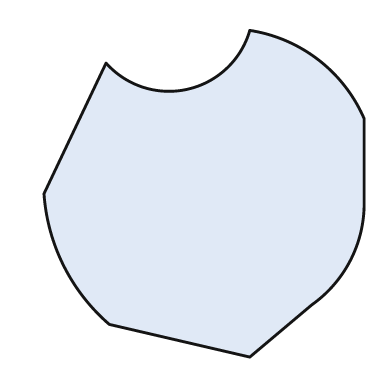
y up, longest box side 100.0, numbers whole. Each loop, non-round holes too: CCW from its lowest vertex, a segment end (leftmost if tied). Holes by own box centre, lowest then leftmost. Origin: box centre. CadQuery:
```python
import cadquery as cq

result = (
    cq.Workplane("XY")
    .moveTo(14.0, -50.0)
    .lineTo(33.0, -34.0)
    .threePointArc((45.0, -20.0), (49.0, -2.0))
    .lineTo(49.0, 23.0)
    .threePointArc((35.0, 41.0), (14.0, 50.0))
    .threePointArc((-5.0, 32.0), (-30.0, 40.0))
    .lineTo(-49.0, 0.0)
    .threePointArc((-43.0, -22.0), (-29.0, -40.0))
    .close()
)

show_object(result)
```